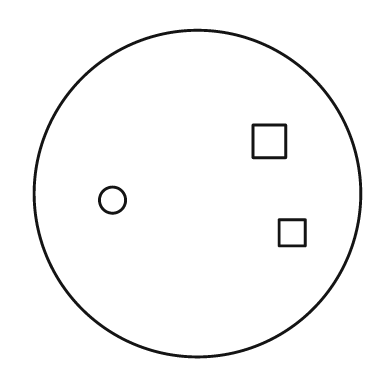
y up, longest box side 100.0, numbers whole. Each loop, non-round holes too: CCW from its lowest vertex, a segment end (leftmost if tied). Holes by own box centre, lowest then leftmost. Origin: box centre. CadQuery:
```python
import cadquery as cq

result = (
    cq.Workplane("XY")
    .moveTo(0.0, 0.0)
    .circle(50.0)
    .moveTo(25.0, -16.0)
    .lineTo(33.0, -16.0)
    .lineTo(33.0, -8.0)
    .lineTo(25.0, -8.0)
    .close()
    .moveTo(-26.0, -2.0)
    .circle(4.0)
    .moveTo(17.0, 11.0)
    .lineTo(27.0, 11.0)
    .lineTo(27.0, 21.0)
    .lineTo(17.0, 21.0)
    .close()
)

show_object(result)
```